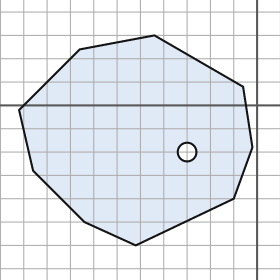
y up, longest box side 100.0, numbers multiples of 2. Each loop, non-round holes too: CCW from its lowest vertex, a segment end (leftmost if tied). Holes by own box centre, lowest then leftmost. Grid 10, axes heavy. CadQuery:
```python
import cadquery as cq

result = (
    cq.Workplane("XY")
    .moveTo(-52.0, -60.0)
    .lineTo(-10.0, -40.0)
    .lineTo(-2.0, -18.0)
    .lineTo(-6.0, 8.0)
    .lineTo(-44.0, 30.0)
    .lineTo(-76.0, 24.0)
    .lineTo(-102.0, -2.0)
    .lineTo(-96.0, -28.0)
    .lineTo(-74.0, -50.0)
    .close()
    .moveTo(-30.0, -20.0)
    .circle(4.0)
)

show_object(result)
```